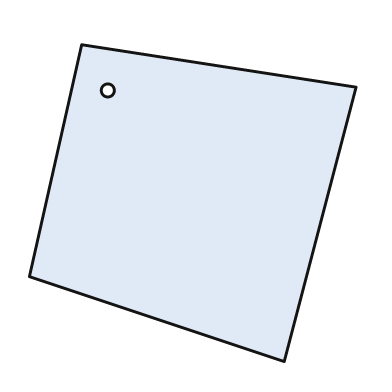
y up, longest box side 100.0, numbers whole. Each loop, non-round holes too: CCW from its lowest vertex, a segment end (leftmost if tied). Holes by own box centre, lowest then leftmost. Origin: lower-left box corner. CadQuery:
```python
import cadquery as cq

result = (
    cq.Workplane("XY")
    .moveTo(78.0, 0.0)
    .lineTo(100.0, 84.0)
    .lineTo(16.0, 97.0)
    .lineTo(0.0, 26.0)
    .close()
    .moveTo(24.0, 83.0)
    .circle(2.0)
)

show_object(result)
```